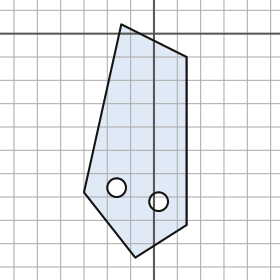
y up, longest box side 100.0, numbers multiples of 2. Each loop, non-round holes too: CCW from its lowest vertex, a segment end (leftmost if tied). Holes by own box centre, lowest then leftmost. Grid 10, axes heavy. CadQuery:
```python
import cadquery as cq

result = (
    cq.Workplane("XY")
    .moveTo(-8.0, -96.0)
    .lineTo(14.0, -82.0)
    .lineTo(14.0, -10.0)
    .lineTo(-14.0, 4.0)
    .lineTo(-30.0, -68.0)
    .close()
    .moveTo(2.0, -72.0)
    .circle(4.0)
    .moveTo(-16.0, -66.0)
    .circle(4.0)
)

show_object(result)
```